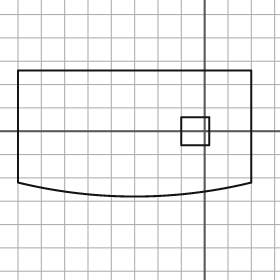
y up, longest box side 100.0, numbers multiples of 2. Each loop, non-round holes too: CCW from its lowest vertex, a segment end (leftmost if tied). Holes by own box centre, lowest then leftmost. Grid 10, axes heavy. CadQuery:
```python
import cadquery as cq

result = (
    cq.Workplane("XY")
    .moveTo(-80.0, -22.0)
    .threePointArc((-30.0, -28.0), (20.0, -22.0))
    .lineTo(20.0, 26.0)
    .lineTo(-80.0, 26.0)
    .close()
    .moveTo(-10.0, -6.0)
    .lineTo(2.0, -6.0)
    .lineTo(2.0, 6.0)
    .lineTo(-10.0, 6.0)
    .close()
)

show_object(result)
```